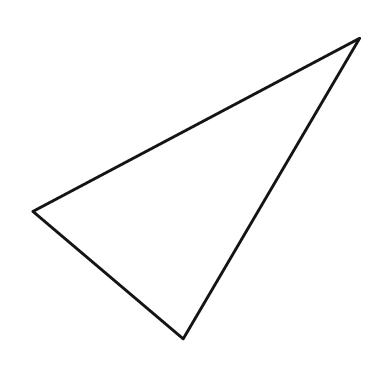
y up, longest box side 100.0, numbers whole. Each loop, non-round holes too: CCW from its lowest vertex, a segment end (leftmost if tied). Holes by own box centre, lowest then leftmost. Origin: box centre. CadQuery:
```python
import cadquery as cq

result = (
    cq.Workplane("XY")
    .moveTo(-4.0, -46.0)
    .lineTo(50.0, 46.0)
    .lineTo(-50.0, -7.0)
    .close()
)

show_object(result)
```